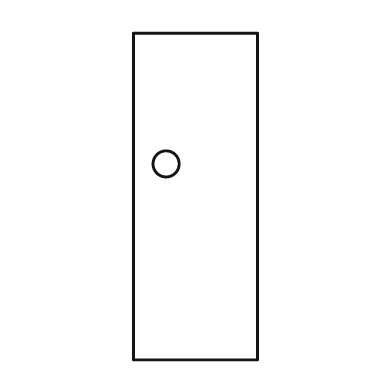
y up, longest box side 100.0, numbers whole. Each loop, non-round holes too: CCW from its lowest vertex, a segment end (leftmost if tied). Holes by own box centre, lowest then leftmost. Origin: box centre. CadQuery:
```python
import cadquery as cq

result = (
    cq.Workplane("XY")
    .moveTo(-19.0, -50.0)
    .lineTo(19.0, -50.0)
    .lineTo(19.0, 50.0)
    .lineTo(-19.0, 50.0)
    .close()
    .moveTo(-9.0, 10.0)
    .circle(4.0)
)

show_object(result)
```